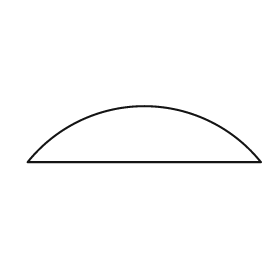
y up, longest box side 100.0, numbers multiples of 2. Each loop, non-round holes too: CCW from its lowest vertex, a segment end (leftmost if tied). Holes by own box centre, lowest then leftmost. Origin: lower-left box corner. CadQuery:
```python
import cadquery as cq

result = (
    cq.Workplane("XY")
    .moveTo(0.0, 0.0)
    .lineTo(100.0, 0.0)
    .threePointArc((50.0, 24.0), (0.0, 0.0))
    .close()
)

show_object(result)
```